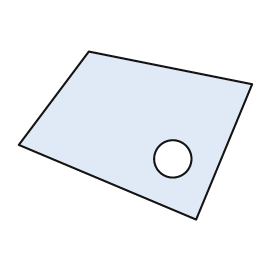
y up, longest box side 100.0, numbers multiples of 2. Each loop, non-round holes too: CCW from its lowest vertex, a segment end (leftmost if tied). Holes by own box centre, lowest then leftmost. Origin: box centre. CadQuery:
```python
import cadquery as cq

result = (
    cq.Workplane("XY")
    .moveTo(26.0, -36.0)
    .lineTo(50.0, 22.0)
    .lineTo(-20.0, 36.0)
    .lineTo(-50.0, -4.0)
    .close()
    .moveTo(16.0, -10.0)
    .circle(8.0)
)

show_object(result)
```